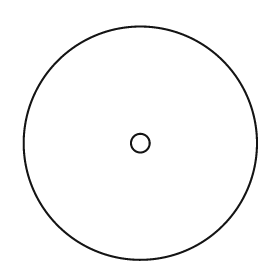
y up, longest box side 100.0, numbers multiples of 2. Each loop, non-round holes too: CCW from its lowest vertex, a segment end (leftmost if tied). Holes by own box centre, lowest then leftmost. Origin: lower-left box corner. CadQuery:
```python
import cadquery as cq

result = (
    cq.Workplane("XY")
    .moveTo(50.0, 50.0)
    .circle(50.0)
    .moveTo(50.0, 50.0)
    .circle(4.0)
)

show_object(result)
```